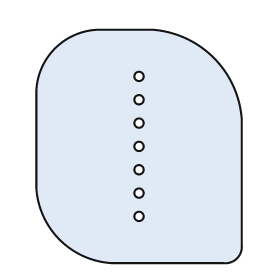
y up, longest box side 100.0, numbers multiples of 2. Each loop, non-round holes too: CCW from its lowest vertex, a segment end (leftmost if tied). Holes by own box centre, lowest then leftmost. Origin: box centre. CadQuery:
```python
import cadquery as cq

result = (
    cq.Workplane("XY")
    .moveTo(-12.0, -50.0)
    .lineTo(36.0, -50.0)
    .threePointArc((42.0, -48.0), (44.0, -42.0))
    .lineTo(44.0, 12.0)
    .threePointArc((32.0, 38.0), (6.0, 50.0))
    .lineTo(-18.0, 50.0)
    .threePointArc((-36.0, 42.0), (-44.0, 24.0))
    .lineTo(-44.0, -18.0)
    .threePointArc((-34.0, -40.0), (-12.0, -50.0))
    .close()
    .moveTo(0.0, -30.0)
    .circle(2.0)
    .moveTo(0.0, -20.0)
    .circle(2.0)
    .moveTo(0.0, -10.0)
    .circle(2.0)
    .moveTo(0.0, 0.0)
    .circle(2.0)
    .moveTo(0.0, 10.0)
    .circle(2.0)
    .moveTo(0.0, 20.0)
    .circle(2.0)
    .moveTo(0.0, 30.0)
    .circle(2.0)
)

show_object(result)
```